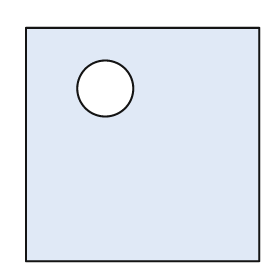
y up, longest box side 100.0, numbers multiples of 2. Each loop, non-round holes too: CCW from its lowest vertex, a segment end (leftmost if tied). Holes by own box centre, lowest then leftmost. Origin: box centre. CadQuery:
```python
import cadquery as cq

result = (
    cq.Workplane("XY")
    .moveTo(-50.0, -50.0)
    .lineTo(50.0, -50.0)
    .lineTo(50.0, 50.0)
    .lineTo(-50.0, 50.0)
    .close()
    .moveTo(-16.0, 24.0)
    .circle(12.0)
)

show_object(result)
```